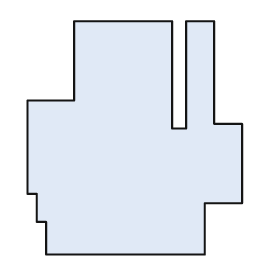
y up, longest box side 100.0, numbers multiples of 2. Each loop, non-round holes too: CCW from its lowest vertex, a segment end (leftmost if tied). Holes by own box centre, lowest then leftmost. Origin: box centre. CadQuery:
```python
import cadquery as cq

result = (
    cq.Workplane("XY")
    .moveTo(-38.0, -50.0)
    .lineTo(30.0, -50.0)
    .lineTo(30.0, -28.0)
    .lineTo(46.0, -28.0)
    .lineTo(46.0, 6.0)
    .lineTo(34.0, 6.0)
    .lineTo(34.0, 50.0)
    .lineTo(22.0, 50.0)
    .lineTo(22.0, 4.0)
    .lineTo(16.0, 4.0)
    .lineTo(16.0, 50.0)
    .lineTo(-26.0, 50.0)
    .lineTo(-26.0, 16.0)
    .lineTo(-46.0, 16.0)
    .lineTo(-46.0, -24.0)
    .lineTo(-42.0, -24.0)
    .lineTo(-42.0, -36.0)
    .lineTo(-38.0, -36.0)
    .close()
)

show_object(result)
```